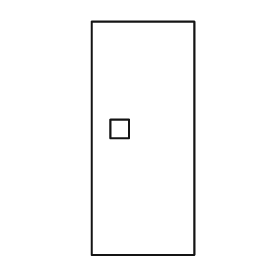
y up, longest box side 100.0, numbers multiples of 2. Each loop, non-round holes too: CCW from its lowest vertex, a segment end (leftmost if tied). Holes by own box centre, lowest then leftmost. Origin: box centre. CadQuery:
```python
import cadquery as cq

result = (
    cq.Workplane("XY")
    .moveTo(-22.0, -50.0)
    .lineTo(22.0, -50.0)
    .lineTo(22.0, 50.0)
    .lineTo(-22.0, 50.0)
    .close()
    .moveTo(-14.0, 0.0)
    .lineTo(-6.0, 0.0)
    .lineTo(-6.0, 8.0)
    .lineTo(-14.0, 8.0)
    .close()
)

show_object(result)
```